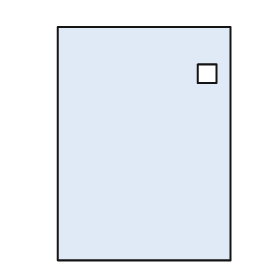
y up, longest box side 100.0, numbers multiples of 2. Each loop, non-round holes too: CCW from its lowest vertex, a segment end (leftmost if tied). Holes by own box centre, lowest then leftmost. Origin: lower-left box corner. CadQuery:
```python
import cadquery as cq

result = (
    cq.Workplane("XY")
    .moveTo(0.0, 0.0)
    .lineTo(74.0, 0.0)
    .lineTo(74.0, 100.0)
    .lineTo(0.0, 100.0)
    .close()
    .moveTo(60.0, 76.0)
    .lineTo(68.0, 76.0)
    .lineTo(68.0, 84.0)
    .lineTo(60.0, 84.0)
    .close()
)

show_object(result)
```